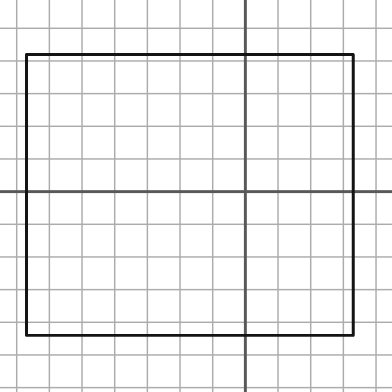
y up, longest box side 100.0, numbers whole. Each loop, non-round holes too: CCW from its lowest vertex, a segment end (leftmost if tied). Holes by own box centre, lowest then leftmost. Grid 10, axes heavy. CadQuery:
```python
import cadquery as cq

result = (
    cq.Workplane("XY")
    .moveTo(-67.0, -44.0)
    .lineTo(33.0, -44.0)
    .lineTo(33.0, 42.0)
    .lineTo(-67.0, 42.0)
    .close()
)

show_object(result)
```